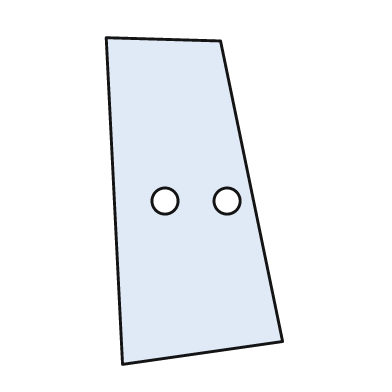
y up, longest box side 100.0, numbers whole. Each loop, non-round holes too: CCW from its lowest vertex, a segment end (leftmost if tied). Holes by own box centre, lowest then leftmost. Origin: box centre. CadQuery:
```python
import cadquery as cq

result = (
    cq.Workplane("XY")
    .moveTo(-22.0, -50.0)
    .lineTo(27.0, -43.0)
    .lineTo(8.0, 49.0)
    .lineTo(-27.0, 50.0)
    .close()
    .moveTo(-9.0, 0.0)
    .circle(4.0)
    .moveTo(10.0, 0.0)
    .circle(4.0)
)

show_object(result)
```